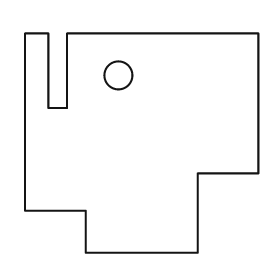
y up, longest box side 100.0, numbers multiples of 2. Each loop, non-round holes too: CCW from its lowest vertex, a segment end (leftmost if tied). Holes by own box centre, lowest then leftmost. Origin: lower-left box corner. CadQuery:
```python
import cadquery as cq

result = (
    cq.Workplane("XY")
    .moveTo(26.0, 0.0)
    .lineTo(74.0, 0.0)
    .lineTo(74.0, 34.0)
    .lineTo(100.0, 34.0)
    .lineTo(100.0, 94.0)
    .lineTo(18.0, 94.0)
    .lineTo(18.0, 62.0)
    .lineTo(10.0, 62.0)
    .lineTo(10.0, 94.0)
    .lineTo(0.0, 94.0)
    .lineTo(0.0, 18.0)
    .lineTo(26.0, 18.0)
    .close()
    .moveTo(40.0, 76.0)
    .circle(6.0)
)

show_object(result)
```